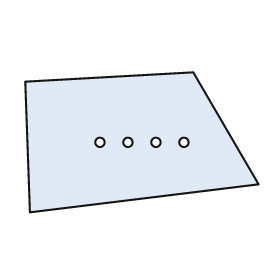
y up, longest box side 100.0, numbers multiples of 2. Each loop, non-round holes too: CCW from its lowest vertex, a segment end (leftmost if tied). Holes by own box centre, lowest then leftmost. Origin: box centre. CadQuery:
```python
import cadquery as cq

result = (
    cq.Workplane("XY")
    .moveTo(-48.0, -30.0)
    .lineTo(50.0, -18.0)
    .lineTo(22.0, 30.0)
    .lineTo(-50.0, 26.0)
    .close()
    .moveTo(-18.0, 0.0)
    .circle(2.0)
    .moveTo(-6.0, 0.0)
    .circle(2.0)
    .moveTo(6.0, 0.0)
    .circle(2.0)
    .moveTo(18.0, 0.0)
    .circle(2.0)
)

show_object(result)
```